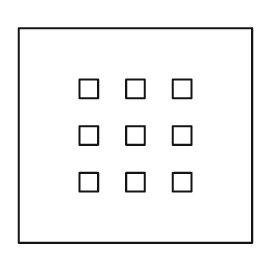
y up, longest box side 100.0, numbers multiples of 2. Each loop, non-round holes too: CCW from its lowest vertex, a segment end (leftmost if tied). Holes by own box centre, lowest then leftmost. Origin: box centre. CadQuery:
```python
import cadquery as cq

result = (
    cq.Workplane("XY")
    .moveTo(-50.0, -46.0)
    .lineTo(50.0, -46.0)
    .lineTo(50.0, 46.0)
    .lineTo(-50.0, 46.0)
    .close()
    .moveTo(-24.0, -24.0)
    .lineTo(-16.0, -24.0)
    .lineTo(-16.0, -16.0)
    .lineTo(-24.0, -16.0)
    .close()
    .moveTo(-4.0, -24.0)
    .lineTo(4.0, -24.0)
    .lineTo(4.0, -16.0)
    .lineTo(-4.0, -16.0)
    .close()
    .moveTo(16.0, -24.0)
    .lineTo(24.0, -24.0)
    .lineTo(24.0, -16.0)
    .lineTo(16.0, -16.0)
    .close()
    .moveTo(-24.0, -4.0)
    .lineTo(-16.0, -4.0)
    .lineTo(-16.0, 4.0)
    .lineTo(-24.0, 4.0)
    .close()
    .moveTo(-4.0, -4.0)
    .lineTo(4.0, -4.0)
    .lineTo(4.0, 4.0)
    .lineTo(-4.0, 4.0)
    .close()
    .moveTo(16.0, -4.0)
    .lineTo(24.0, -4.0)
    .lineTo(24.0, 4.0)
    .lineTo(16.0, 4.0)
    .close()
    .moveTo(-24.0, 16.0)
    .lineTo(-16.0, 16.0)
    .lineTo(-16.0, 24.0)
    .lineTo(-24.0, 24.0)
    .close()
    .moveTo(-4.0, 16.0)
    .lineTo(4.0, 16.0)
    .lineTo(4.0, 24.0)
    .lineTo(-4.0, 24.0)
    .close()
    .moveTo(16.0, 16.0)
    .lineTo(24.0, 16.0)
    .lineTo(24.0, 24.0)
    .lineTo(16.0, 24.0)
    .close()
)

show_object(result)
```